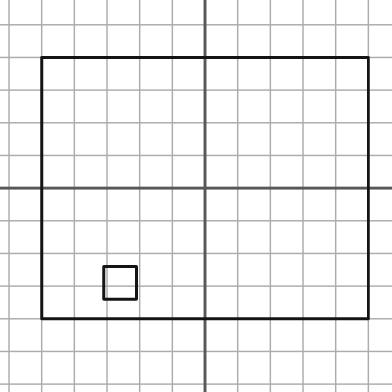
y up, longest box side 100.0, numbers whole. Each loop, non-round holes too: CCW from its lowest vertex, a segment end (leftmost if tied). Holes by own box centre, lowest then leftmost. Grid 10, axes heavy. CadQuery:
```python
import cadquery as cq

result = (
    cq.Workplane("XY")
    .moveTo(-50.0, -40.0)
    .lineTo(50.0, -40.0)
    .lineTo(50.0, 40.0)
    .lineTo(-50.0, 40.0)
    .close()
    .moveTo(-31.0, -34.0)
    .lineTo(-21.0, -34.0)
    .lineTo(-21.0, -24.0)
    .lineTo(-31.0, -24.0)
    .close()
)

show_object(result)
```